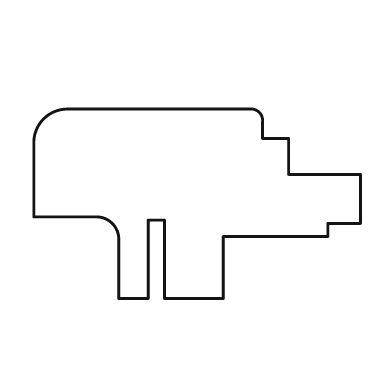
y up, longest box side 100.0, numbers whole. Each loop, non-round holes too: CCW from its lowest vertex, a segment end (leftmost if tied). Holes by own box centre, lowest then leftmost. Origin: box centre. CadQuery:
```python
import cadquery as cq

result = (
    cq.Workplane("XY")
    .moveTo(-24.0, -29.0)
    .lineTo(-15.0, -29.0)
    .lineTo(-15.0, -5.0)
    .lineTo(-10.0, -5.0)
    .lineTo(-10.0, -29.0)
    .lineTo(8.0, -29.0)
    .lineTo(8.0, -10.0)
    .lineTo(40.0, -10.0)
    .lineTo(40.0, -6.0)
    .lineTo(50.0, -6.0)
    .lineTo(50.0, 9.0)
    .lineTo(28.0, 9.0)
    .lineTo(28.0, 20.0)
    .lineTo(20.0, 20.0)
    .lineTo(20.0, 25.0)
    .threePointArc((19.0, 28.0), (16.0, 29.0))
    .lineTo(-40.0, 29.0)
    .threePointArc((-47.0, 26.0), (-50.0, 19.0))
    .lineTo(-50.0, -4.0)
    .lineTo(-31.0, -4.0)
    .threePointArc((-26.0, -6.0), (-24.0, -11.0))
    .close()
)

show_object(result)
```